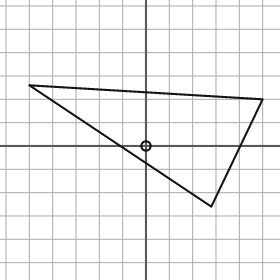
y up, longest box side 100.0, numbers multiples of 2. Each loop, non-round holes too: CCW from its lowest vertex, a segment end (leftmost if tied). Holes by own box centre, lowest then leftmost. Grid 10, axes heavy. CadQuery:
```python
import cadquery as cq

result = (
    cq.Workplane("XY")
    .moveTo(28.0, -26.0)
    .lineTo(50.0, 20.0)
    .lineTo(-50.0, 26.0)
    .close()
    .moveTo(0.0, 0.0)
    .circle(2.0)
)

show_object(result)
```